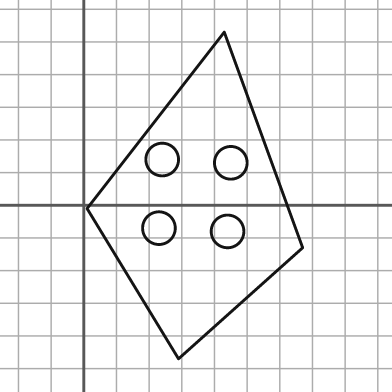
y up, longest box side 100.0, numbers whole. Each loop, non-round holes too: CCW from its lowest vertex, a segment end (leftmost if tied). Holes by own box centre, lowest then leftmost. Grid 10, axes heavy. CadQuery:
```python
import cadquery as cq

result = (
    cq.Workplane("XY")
    .moveTo(29.0, -47.0)
    .lineTo(67.0, -13.0)
    .lineTo(43.0, 53.0)
    .lineTo(1.0, -1.0)
    .close()
    .moveTo(44.0, -8.0)
    .circle(5.0)
    .moveTo(23.0, -7.0)
    .circle(5.0)
    .moveTo(45.0, 13.0)
    .circle(5.0)
    .moveTo(24.0, 14.0)
    .circle(5.0)
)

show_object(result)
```